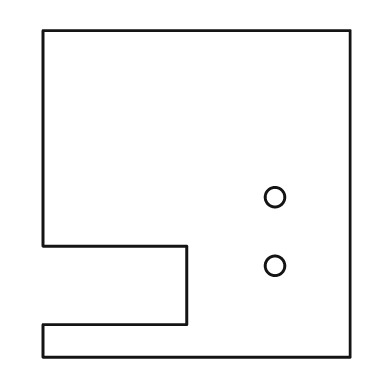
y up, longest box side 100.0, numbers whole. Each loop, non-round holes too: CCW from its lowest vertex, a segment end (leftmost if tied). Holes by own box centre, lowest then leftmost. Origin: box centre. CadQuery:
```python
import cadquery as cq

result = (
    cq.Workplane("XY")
    .moveTo(-47.0, -50.0)
    .lineTo(47.0, -50.0)
    .lineTo(47.0, 50.0)
    .lineTo(-47.0, 50.0)
    .lineTo(-47.0, -16.0)
    .lineTo(-3.0, -16.0)
    .lineTo(-3.0, -40.0)
    .lineTo(-47.0, -40.0)
    .close()
    .moveTo(24.0, -22.0)
    .circle(3.0)
    .moveTo(24.0, -1.0)
    .circle(3.0)
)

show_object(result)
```